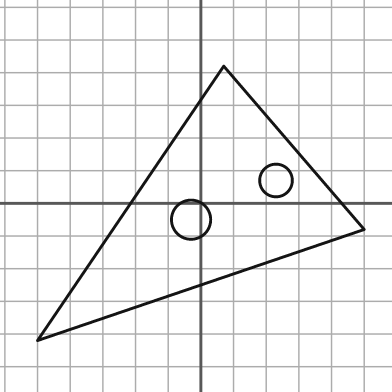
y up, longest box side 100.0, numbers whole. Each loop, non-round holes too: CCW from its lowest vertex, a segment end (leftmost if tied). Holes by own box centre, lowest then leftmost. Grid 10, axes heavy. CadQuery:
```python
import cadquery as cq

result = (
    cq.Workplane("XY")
    .moveTo(-50.0, -42.0)
    .lineTo(50.0, -8.0)
    .lineTo(7.0, 42.0)
    .close()
    .moveTo(-3.0, -5.0)
    .circle(6.0)
    .moveTo(23.0, 7.0)
    .circle(5.0)
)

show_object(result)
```